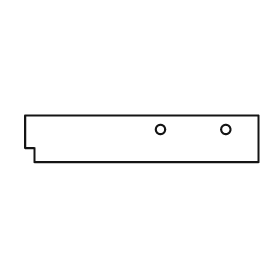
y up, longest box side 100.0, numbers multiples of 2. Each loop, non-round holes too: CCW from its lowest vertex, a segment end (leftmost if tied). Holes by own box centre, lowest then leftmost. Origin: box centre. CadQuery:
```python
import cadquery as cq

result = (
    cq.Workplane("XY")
    .moveTo(-46.0, -10.0)
    .lineTo(50.0, -10.0)
    .lineTo(50.0, 10.0)
    .lineTo(-50.0, 10.0)
    .lineTo(-50.0, -4.0)
    .lineTo(-46.0, -4.0)
    .close()
    .moveTo(8.0, 4.0)
    .circle(2.0)
    .moveTo(36.0, 4.0)
    .circle(2.0)
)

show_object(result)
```